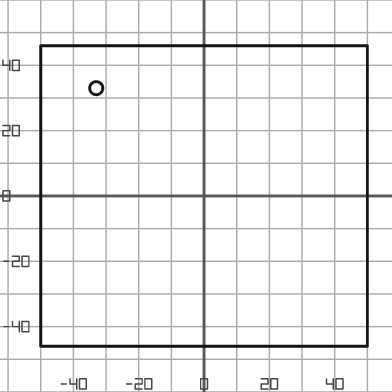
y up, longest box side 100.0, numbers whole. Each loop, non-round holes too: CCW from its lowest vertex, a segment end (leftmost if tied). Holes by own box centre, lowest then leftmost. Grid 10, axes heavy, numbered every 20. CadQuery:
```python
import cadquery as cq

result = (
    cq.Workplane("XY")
    .moveTo(-50.0, -46.0)
    .lineTo(50.0, -46.0)
    .lineTo(50.0, 46.0)
    .lineTo(-50.0, 46.0)
    .close()
    .moveTo(-33.0, 33.0)
    .circle(2.0)
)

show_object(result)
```